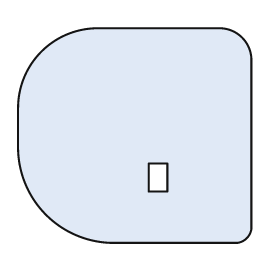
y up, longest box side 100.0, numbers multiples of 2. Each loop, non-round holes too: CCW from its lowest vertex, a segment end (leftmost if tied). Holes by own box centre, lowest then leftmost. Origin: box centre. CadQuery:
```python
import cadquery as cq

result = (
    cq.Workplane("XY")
    .moveTo(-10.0, -46.0)
    .lineTo(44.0, -46.0)
    .threePointArc((48.0, -44.0), (50.0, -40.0))
    .lineTo(50.0, 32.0)
    .threePointArc((46.0, 42.0), (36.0, 46.0))
    .lineTo(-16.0, 46.0)
    .threePointArc((-40.0, 36.0), (-50.0, 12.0))
    .lineTo(-50.0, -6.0)
    .threePointArc((-38.0, -34.0), (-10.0, -46.0))
    .close()
    .moveTo(6.0, -24.0)
    .lineTo(14.0, -24.0)
    .lineTo(14.0, -12.0)
    .lineTo(6.0, -12.0)
    .close()
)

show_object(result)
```